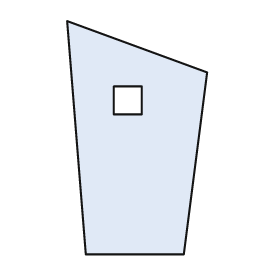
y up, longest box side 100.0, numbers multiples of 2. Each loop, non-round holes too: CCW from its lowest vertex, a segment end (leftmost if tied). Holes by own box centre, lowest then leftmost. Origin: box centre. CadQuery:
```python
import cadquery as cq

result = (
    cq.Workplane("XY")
    .moveTo(-22.0, -50.0)
    .lineTo(20.0, -50.0)
    .lineTo(30.0, 28.0)
    .lineTo(-30.0, 50.0)
    .close()
    .moveTo(-10.0, 10.0)
    .lineTo(2.0, 10.0)
    .lineTo(2.0, 22.0)
    .lineTo(-10.0, 22.0)
    .close()
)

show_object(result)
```